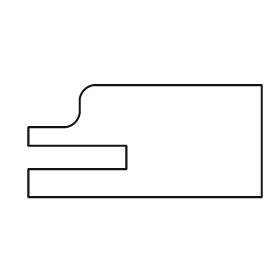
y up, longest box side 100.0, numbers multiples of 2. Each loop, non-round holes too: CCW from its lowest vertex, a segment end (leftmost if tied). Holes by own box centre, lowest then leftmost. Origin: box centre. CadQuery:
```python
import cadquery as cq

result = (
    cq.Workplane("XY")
    .moveTo(-50.0, -24.0)
    .lineTo(50.0, -24.0)
    .lineTo(50.0, 24.0)
    .lineTo(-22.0, 24.0)
    .threePointArc((-26.0, 22.0), (-28.0, 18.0))
    .lineTo(-28.0, 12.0)
    .threePointArc((-30.0, 8.0), (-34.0, 6.0))
    .lineTo(-50.0, 6.0)
    .lineTo(-50.0, -2.0)
    .lineTo(-8.0, -2.0)
    .lineTo(-8.0, -12.0)
    .lineTo(-50.0, -12.0)
    .close()
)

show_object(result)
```